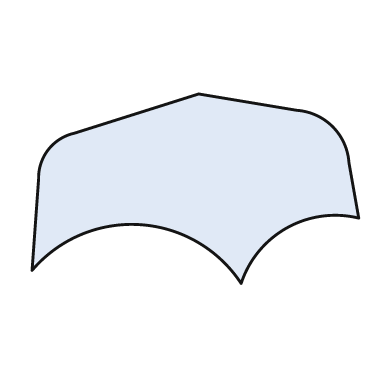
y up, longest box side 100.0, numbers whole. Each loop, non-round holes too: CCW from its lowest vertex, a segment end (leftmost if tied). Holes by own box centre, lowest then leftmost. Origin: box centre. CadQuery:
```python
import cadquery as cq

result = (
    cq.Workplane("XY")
    .moveTo(14.0, -29.0)
    .threePointArc((28.0, -12.0), (50.0, -9.0))
    .lineTo(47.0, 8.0)
    .threePointArc((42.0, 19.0), (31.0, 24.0))
    .lineTo(1.0, 29.0)
    .lineTo(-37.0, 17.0)
    .threePointArc((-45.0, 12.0), (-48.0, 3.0))
    .lineTo(-50.0, -25.0)
    .threePointArc((-17.0, -11.0), (14.0, -29.0))
    .close()
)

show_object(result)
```